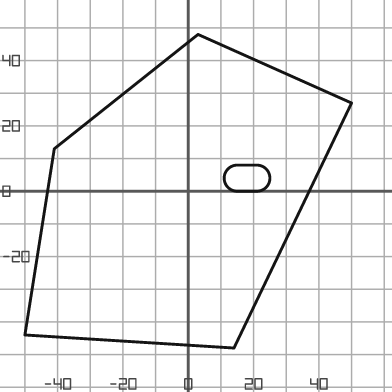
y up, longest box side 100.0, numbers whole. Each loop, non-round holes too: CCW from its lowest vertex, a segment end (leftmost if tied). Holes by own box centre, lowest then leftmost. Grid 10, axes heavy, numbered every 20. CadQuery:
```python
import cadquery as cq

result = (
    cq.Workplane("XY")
    .moveTo(14.0, -48.0)
    .lineTo(50.0, 27.0)
    .lineTo(3.0, 48.0)
    .lineTo(-41.0, 13.0)
    .lineTo(-50.0, -44.0)
    .close()
    .moveTo(15.0, 0.0)
    .lineTo(21.0, 0.0)
    .threePointArc((25.0, 4.0), (21.0, 8.0))
    .lineTo(15.0, 8.0)
    .threePointArc((11.0, 4.0), (15.0, 0.0))
    .close()
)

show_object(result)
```